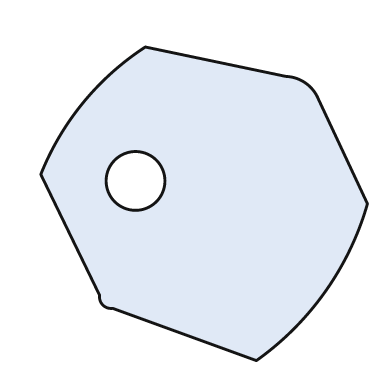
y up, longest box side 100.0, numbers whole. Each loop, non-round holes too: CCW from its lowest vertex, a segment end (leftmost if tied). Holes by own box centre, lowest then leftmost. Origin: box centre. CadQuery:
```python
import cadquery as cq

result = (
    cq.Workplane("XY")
    .moveTo(16.0, -48.0)
    .threePointArc((37.0, -27.0), (50.0, 0.0))
    .lineTo(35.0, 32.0)
    .threePointArc((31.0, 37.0), (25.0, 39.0))
    .lineTo(-18.0, 48.0)
    .threePointArc((-37.0, 31.0), (-50.0, 9.0))
    .lineTo(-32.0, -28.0)
    .threePointArc((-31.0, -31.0), (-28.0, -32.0))
    .close()
    .moveTo(-21.0, 7.0)
    .circle(9.0)
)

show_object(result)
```